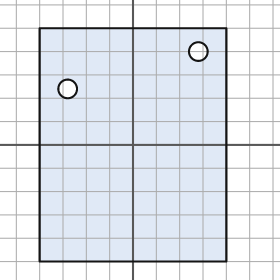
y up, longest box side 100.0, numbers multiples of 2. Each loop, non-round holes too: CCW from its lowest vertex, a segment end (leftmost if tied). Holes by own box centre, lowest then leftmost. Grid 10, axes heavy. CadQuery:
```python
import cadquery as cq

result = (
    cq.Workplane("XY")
    .moveTo(-40.0, -50.0)
    .lineTo(40.0, -50.0)
    .lineTo(40.0, 50.0)
    .lineTo(-40.0, 50.0)
    .close()
    .moveTo(-28.0, 24.0)
    .circle(4.0)
    .moveTo(28.0, 40.0)
    .circle(4.0)
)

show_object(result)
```